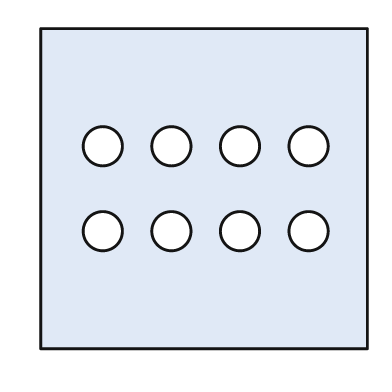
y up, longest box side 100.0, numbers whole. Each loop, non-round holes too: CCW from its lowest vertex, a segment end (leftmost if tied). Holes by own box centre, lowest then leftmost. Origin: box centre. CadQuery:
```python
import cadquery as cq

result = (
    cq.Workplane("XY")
    .moveTo(-50.0, -49.0)
    .lineTo(50.0, -49.0)
    .lineTo(50.0, 49.0)
    .lineTo(-50.0, 49.0)
    .close()
    .moveTo(-31.0, -13.0)
    .circle(6.0)
    .moveTo(-10.0, -13.0)
    .circle(6.0)
    .moveTo(11.0, -13.0)
    .circle(6.0)
    .moveTo(32.0, -13.0)
    .circle(6.0)
    .moveTo(-31.0, 13.0)
    .circle(6.0)
    .moveTo(-10.0, 13.0)
    .circle(6.0)
    .moveTo(11.0, 13.0)
    .circle(6.0)
    .moveTo(32.0, 13.0)
    .circle(6.0)
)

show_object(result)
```